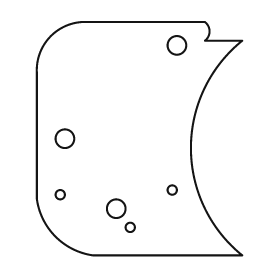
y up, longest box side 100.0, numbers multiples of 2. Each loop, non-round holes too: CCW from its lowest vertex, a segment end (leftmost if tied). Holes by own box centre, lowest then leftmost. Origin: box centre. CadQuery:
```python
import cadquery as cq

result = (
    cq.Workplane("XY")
    .moveTo(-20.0, -50.0)
    .lineTo(44.0, -50.0)
    .threePointArc((22.0, -4.0), (44.0, 42.0))
    .lineTo(28.0, 42.0)
    .threePointArc((30.0, 46.0), (28.0, 50.0))
    .lineTo(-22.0, 50.0)
    .threePointArc((-38.0, 44.0), (-44.0, 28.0))
    .lineTo(-44.0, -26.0)
    .threePointArc((-36.0, -42.0), (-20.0, -50.0))
    .close()
    .moveTo(-4.0, -38.0)
    .circle(2.0)
    .moveTo(-10.0, -30.0)
    .circle(4.0)
    .moveTo(-34.0, -24.0)
    .circle(2.0)
    .moveTo(14.0, -22.0)
    .circle(2.0)
    .moveTo(-32.0, 0.0)
    .circle(4.0)
    .moveTo(16.0, 40.0)
    .circle(4.0)
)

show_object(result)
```